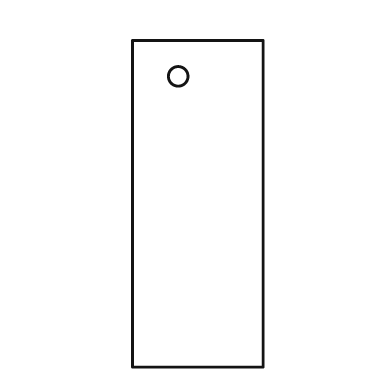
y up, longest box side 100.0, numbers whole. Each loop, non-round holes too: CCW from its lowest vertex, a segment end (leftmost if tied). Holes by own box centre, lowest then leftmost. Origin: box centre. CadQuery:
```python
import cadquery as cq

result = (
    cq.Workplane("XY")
    .moveTo(-20.0, -50.0)
    .lineTo(20.0, -50.0)
    .lineTo(20.0, 50.0)
    .lineTo(-20.0, 50.0)
    .close()
    .moveTo(-6.0, 39.0)
    .circle(3.0)
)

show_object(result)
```